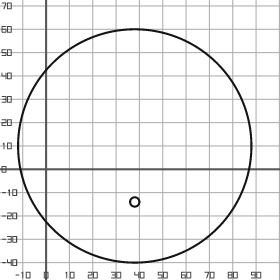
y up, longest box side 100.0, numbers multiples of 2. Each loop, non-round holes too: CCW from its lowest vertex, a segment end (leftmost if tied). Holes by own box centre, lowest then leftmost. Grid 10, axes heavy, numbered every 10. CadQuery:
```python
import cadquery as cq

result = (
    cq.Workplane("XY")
    .moveTo(38.0, 10.0)
    .circle(50.0)
    .moveTo(38.0, -14.0)
    .circle(2.0)
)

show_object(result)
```